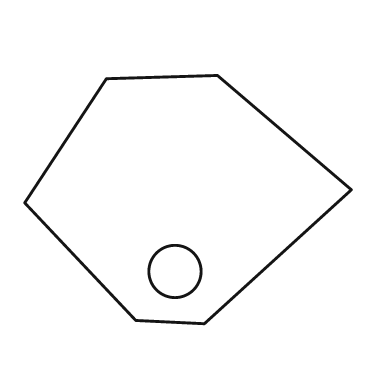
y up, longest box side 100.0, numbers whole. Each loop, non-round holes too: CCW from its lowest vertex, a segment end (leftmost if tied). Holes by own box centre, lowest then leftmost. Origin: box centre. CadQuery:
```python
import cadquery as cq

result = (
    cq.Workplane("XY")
    .moveTo(5.0, -38.0)
    .lineTo(50.0, 3.0)
    .lineTo(9.0, 38.0)
    .lineTo(-25.0, 37.0)
    .lineTo(-50.0, -1.0)
    .lineTo(-16.0, -37.0)
    .close()
    .moveTo(-4.0, -22.0)
    .circle(8.0)
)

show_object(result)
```